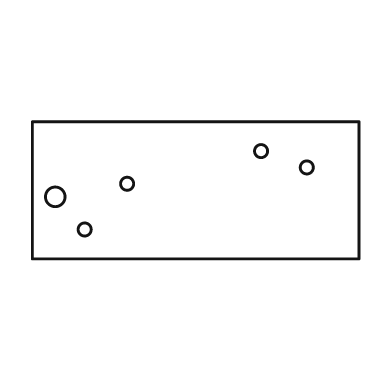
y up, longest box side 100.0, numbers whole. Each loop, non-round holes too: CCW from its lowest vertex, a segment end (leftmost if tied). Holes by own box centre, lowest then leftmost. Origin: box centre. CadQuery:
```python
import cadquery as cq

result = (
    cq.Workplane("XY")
    .moveTo(-50.0, -21.0)
    .lineTo(50.0, -21.0)
    .lineTo(50.0, 21.0)
    .lineTo(-50.0, 21.0)
    .close()
    .moveTo(-34.0, -12.0)
    .circle(2.0)
    .moveTo(-43.0, -2.0)
    .circle(3.0)
    .moveTo(-21.0, 2.0)
    .circle(2.0)
    .moveTo(34.0, 7.0)
    .circle(2.0)
    .moveTo(20.0, 12.0)
    .circle(2.0)
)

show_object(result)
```